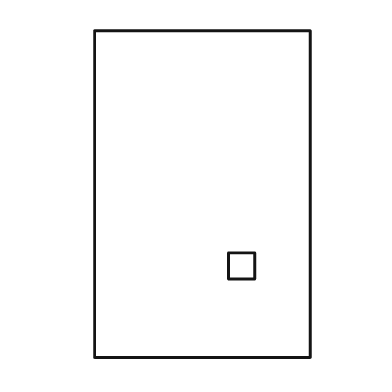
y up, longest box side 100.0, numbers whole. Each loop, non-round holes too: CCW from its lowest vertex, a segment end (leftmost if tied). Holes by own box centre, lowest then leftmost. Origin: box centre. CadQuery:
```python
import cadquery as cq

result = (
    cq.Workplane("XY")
    .moveTo(-33.0, -50.0)
    .lineTo(33.0, -50.0)
    .lineTo(33.0, 50.0)
    .lineTo(-33.0, 50.0)
    .close()
    .moveTo(8.0, -26.0)
    .lineTo(16.0, -26.0)
    .lineTo(16.0, -18.0)
    .lineTo(8.0, -18.0)
    .close()
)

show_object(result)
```